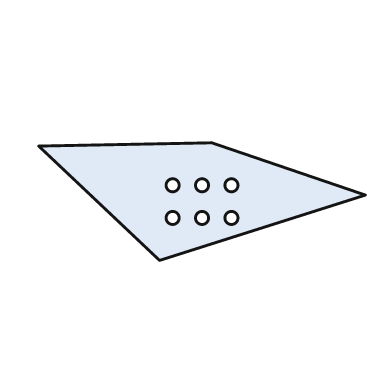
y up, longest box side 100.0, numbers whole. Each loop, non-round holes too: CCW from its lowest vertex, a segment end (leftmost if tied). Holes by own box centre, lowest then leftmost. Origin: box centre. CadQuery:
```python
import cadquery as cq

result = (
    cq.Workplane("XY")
    .moveTo(-13.0, -18.0)
    .lineTo(50.0, 2.0)
    .lineTo(3.0, 18.0)
    .lineTo(-50.0, 17.0)
    .close()
    .moveTo(-9.0, -5.0)
    .circle(2.0)
    .moveTo(0.0, -5.0)
    .circle(2.0)
    .moveTo(9.0, -5.0)
    .circle(2.0)
    .moveTo(-9.0, 5.0)
    .circle(2.0)
    .moveTo(0.0, 5.0)
    .circle(2.0)
    .moveTo(9.0, 5.0)
    .circle(2.0)
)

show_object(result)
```